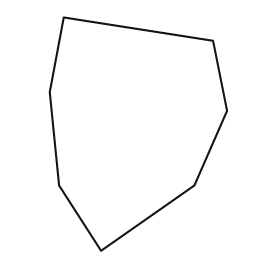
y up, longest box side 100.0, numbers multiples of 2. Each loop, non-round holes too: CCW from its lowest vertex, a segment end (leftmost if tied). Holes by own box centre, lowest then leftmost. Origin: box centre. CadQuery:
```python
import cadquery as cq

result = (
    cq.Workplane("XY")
    .moveTo(-16.0, -50.0)
    .lineTo(24.0, -22.0)
    .lineTo(38.0, 10.0)
    .lineTo(32.0, 40.0)
    .lineTo(-32.0, 50.0)
    .lineTo(-38.0, 18.0)
    .lineTo(-34.0, -22.0)
    .close()
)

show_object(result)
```